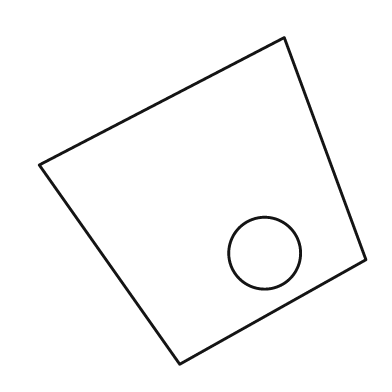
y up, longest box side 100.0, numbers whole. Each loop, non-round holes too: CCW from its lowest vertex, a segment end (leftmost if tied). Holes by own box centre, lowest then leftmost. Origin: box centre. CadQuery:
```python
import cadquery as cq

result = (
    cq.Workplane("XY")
    .moveTo(-7.0, -50.0)
    .lineTo(50.0, -18.0)
    .lineTo(25.0, 50.0)
    .lineTo(-50.0, 11.0)
    .close()
    .moveTo(19.0, -16.0)
    .circle(11.0)
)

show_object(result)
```